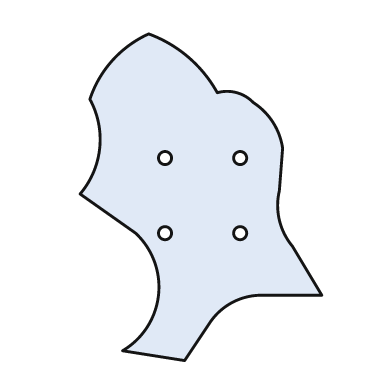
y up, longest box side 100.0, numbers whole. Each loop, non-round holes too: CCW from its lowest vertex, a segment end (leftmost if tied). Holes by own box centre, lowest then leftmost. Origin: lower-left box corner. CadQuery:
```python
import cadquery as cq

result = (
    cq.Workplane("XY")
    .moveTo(32.0, 0.0)
    .lineTo(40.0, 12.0)
    .threePointArc((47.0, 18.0), (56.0, 20.0))
    .lineTo(74.0, 20.0)
    .lineTo(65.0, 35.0)
    .threePointArc((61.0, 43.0), (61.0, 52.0))
    .lineTo(62.0, 65.0)
    .threePointArc((59.0, 73.0), (53.0, 79.0))
    .threePointArc((48.0, 82.0), (42.0, 82.0))
    .threePointArc((33.0, 93.0), (21.0, 100.0))
    .threePointArc((10.0, 92.0), (3.0, 80.0))
    .threePointArc((6.0, 65.0), (0.0, 51.0))
    .lineTo(17.0, 39.0)
    .threePointArc((24.0, 20.0), (13.0, 3.0))
    .close()
    .moveTo(26.0, 39.0)
    .circle(2.0)
    .moveTo(49.0, 39.0)
    .circle(2.0)
    .moveTo(26.0, 62.0)
    .circle(2.0)
    .moveTo(49.0, 62.0)
    .circle(2.0)
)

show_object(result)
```